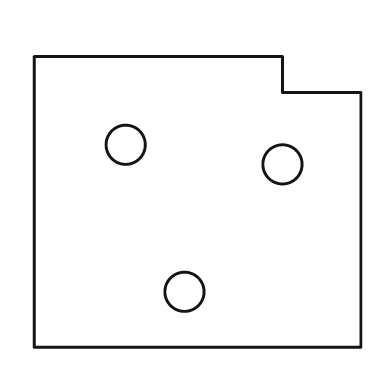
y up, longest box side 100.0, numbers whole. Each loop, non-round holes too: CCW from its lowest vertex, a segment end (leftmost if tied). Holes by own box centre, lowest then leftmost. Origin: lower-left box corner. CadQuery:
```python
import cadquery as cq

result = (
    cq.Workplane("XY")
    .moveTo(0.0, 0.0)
    .lineTo(100.0, 0.0)
    .lineTo(100.0, 78.0)
    .lineTo(76.0, 78.0)
    .lineTo(76.0, 89.0)
    .lineTo(0.0, 89.0)
    .close()
    .moveTo(46.0, 17.0)
    .circle(6.0)
    .moveTo(76.0, 56.0)
    .circle(6.0)
    .moveTo(28.0, 62.0)
    .circle(6.0)
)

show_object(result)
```